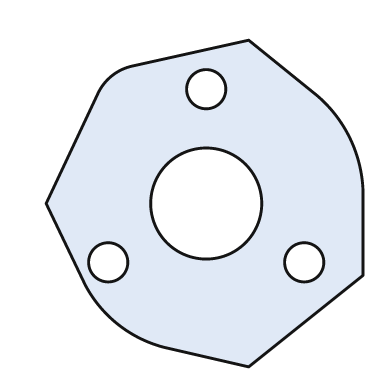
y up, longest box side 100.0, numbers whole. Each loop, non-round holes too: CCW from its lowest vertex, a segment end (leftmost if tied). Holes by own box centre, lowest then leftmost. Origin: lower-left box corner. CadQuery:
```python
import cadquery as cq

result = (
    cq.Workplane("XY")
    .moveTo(62.0, 0.0)
    .lineTo(97.0, 28.0)
    .lineTo(97.0, 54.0)
    .threePointArc((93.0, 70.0), (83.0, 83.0))
    .lineTo(62.0, 100.0)
    .lineTo(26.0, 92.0)
    .threePointArc((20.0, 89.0), (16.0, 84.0))
    .lineTo(0.0, 50.0)
    .lineTo(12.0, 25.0)
    .threePointArc((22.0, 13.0), (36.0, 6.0))
    .close()
    .moveTo(19.0, 32.0)
    .circle(6.0)
    .moveTo(79.0, 32.0)
    .circle(6.0)
    .moveTo(49.0, 50.0)
    .circle(17.0)
    .moveTo(49.0, 85.0)
    .circle(6.0)
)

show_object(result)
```